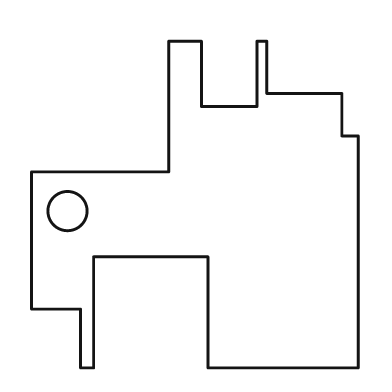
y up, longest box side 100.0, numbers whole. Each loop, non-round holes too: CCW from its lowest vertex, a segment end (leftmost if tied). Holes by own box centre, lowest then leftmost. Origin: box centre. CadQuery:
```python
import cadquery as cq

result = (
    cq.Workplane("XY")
    .moveTo(-35.0, -50.0)
    .lineTo(-31.0, -50.0)
    .lineTo(-31.0, -16.0)
    .lineTo(4.0, -16.0)
    .lineTo(4.0, -50.0)
    .lineTo(50.0, -50.0)
    .lineTo(50.0, 21.0)
    .lineTo(45.0, 21.0)
    .lineTo(45.0, 34.0)
    .lineTo(22.0, 34.0)
    .lineTo(22.0, 50.0)
    .lineTo(19.0, 50.0)
    .lineTo(19.0, 30.0)
    .lineTo(2.0, 30.0)
    .lineTo(2.0, 50.0)
    .lineTo(-8.0, 50.0)
    .lineTo(-8.0, 10.0)
    .lineTo(-50.0, 10.0)
    .lineTo(-50.0, -32.0)
    .lineTo(-35.0, -32.0)
    .close()
    .moveTo(-39.0, -2.0)
    .circle(6.0)
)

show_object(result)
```